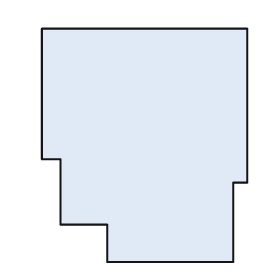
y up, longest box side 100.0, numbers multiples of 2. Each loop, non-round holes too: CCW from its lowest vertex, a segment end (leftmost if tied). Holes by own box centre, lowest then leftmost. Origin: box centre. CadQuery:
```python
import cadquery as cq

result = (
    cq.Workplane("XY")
    .moveTo(-16.0, -50.0)
    .lineTo(38.0, -50.0)
    .lineTo(38.0, -16.0)
    .lineTo(44.0, -16.0)
    .lineTo(44.0, 50.0)
    .lineTo(-44.0, 50.0)
    .lineTo(-44.0, -6.0)
    .lineTo(-36.0, -6.0)
    .lineTo(-36.0, -34.0)
    .lineTo(-16.0, -34.0)
    .close()
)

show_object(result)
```